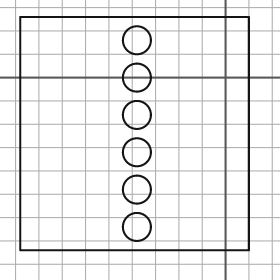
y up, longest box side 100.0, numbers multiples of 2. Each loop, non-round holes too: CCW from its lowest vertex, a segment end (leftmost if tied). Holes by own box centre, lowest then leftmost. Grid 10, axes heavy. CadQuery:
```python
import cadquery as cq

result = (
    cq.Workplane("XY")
    .moveTo(-88.0, -74.0)
    .lineTo(10.0, -74.0)
    .lineTo(10.0, 26.0)
    .lineTo(-88.0, 26.0)
    .close()
    .moveTo(-38.0, -64.0)
    .circle(6.0)
    .moveTo(-38.0, -48.0)
    .circle(6.0)
    .moveTo(-38.0, -32.0)
    .circle(6.0)
    .moveTo(-38.0, -16.0)
    .circle(6.0)
    .moveTo(-38.0, 0.0)
    .circle(6.0)
    .moveTo(-38.0, 16.0)
    .circle(6.0)
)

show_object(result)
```